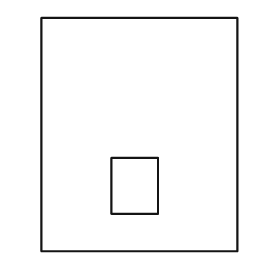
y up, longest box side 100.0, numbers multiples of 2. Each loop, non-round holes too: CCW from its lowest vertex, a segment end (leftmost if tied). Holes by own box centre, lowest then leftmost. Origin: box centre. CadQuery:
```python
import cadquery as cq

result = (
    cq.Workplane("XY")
    .moveTo(-42.0, -50.0)
    .lineTo(42.0, -50.0)
    .lineTo(42.0, 50.0)
    .lineTo(-42.0, 50.0)
    .close()
    .moveTo(-12.0, -34.0)
    .lineTo(8.0, -34.0)
    .lineTo(8.0, -10.0)
    .lineTo(-12.0, -10.0)
    .close()
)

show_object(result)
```